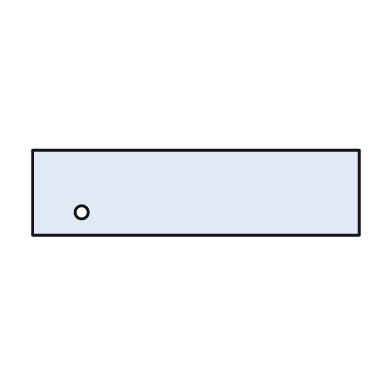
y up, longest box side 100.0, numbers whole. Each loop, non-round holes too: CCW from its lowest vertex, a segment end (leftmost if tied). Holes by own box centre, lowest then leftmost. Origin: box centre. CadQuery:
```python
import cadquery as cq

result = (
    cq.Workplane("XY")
    .moveTo(-50.0, -13.0)
    .lineTo(50.0, -13.0)
    .lineTo(50.0, 13.0)
    .lineTo(-50.0, 13.0)
    .close()
    .moveTo(-35.0, -6.0)
    .circle(2.0)
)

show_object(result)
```